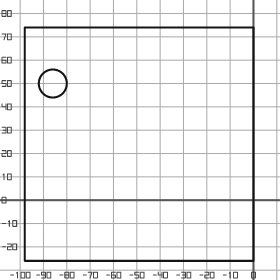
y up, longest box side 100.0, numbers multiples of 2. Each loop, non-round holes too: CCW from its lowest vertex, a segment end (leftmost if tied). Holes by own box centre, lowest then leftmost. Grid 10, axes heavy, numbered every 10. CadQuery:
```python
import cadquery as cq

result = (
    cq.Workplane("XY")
    .moveTo(-98.0, -26.0)
    .lineTo(0.0, -26.0)
    .lineTo(0.0, 74.0)
    .lineTo(-98.0, 74.0)
    .close()
    .moveTo(-86.0, 50.0)
    .circle(6.0)
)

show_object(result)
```